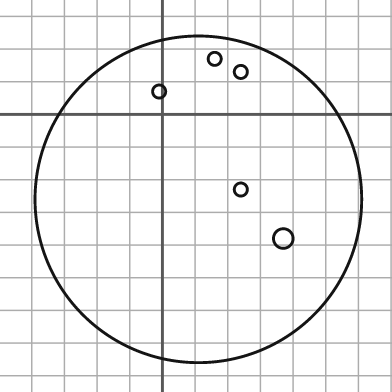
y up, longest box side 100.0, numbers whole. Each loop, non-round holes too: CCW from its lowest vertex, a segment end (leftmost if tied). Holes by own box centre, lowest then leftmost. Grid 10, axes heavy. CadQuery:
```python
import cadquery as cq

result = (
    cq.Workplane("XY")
    .moveTo(11.0, -26.0)
    .circle(50.0)
    .moveTo(37.0, -38.0)
    .circle(3.0)
    .moveTo(24.0, -23.0)
    .circle(2.0)
    .moveTo(-1.0, 7.0)
    .circle(2.0)
    .moveTo(24.0, 13.0)
    .circle(2.0)
    .moveTo(16.0, 17.0)
    .circle(2.0)
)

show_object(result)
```